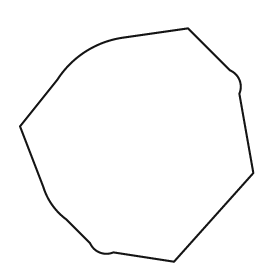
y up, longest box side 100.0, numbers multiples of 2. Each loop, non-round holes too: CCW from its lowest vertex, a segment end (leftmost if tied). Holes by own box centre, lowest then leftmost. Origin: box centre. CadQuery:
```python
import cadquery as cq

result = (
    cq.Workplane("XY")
    .moveTo(16.0, -50.0)
    .lineTo(50.0, -12.0)
    .lineTo(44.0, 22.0)
    .threePointArc((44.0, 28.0), (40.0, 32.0))
    .lineTo(22.0, 50.0)
    .lineTo(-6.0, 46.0)
    .threePointArc((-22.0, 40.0), (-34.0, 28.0))
    .lineTo(-50.0, 8.0)
    .lineTo(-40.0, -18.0)
    .threePointArc((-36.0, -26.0), (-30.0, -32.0))
    .lineTo(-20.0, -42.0)
    .threePointArc((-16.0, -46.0), (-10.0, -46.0))
    .close()
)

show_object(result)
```